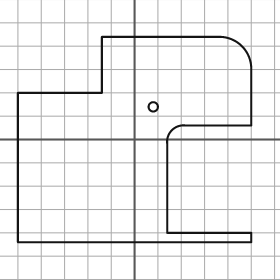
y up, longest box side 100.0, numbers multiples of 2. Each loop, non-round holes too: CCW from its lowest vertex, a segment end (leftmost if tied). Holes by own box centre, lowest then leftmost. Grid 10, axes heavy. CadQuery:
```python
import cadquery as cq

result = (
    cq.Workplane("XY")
    .moveTo(-50.0, -44.0)
    .lineTo(50.0, -44.0)
    .lineTo(50.0, -40.0)
    .lineTo(14.0, -40.0)
    .lineTo(14.0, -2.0)
    .threePointArc((16.0, 4.0), (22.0, 6.0))
    .lineTo(50.0, 6.0)
    .lineTo(50.0, 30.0)
    .threePointArc((46.0, 40.0), (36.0, 44.0))
    .lineTo(-14.0, 44.0)
    .lineTo(-14.0, 20.0)
    .lineTo(-50.0, 20.0)
    .close()
    .moveTo(8.0, 14.0)
    .circle(2.0)
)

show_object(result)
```